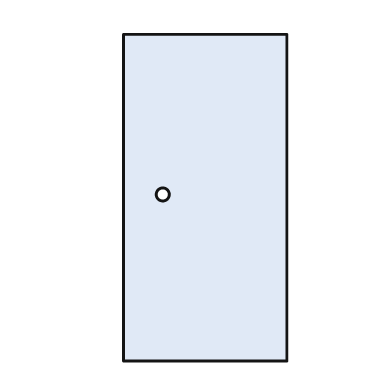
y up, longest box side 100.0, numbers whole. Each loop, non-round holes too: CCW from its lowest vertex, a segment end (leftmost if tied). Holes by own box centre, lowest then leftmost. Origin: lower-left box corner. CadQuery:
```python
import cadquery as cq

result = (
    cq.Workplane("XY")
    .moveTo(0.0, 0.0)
    .lineTo(50.0, 0.0)
    .lineTo(50.0, 100.0)
    .lineTo(0.0, 100.0)
    .close()
    .moveTo(12.0, 51.0)
    .circle(2.0)
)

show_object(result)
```